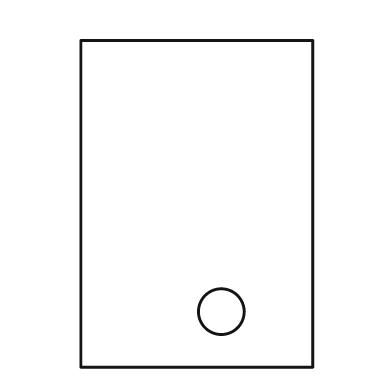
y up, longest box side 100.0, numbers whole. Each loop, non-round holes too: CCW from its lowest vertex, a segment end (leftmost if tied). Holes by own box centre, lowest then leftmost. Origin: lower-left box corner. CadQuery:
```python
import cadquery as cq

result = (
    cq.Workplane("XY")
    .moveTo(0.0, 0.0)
    .lineTo(71.0, 0.0)
    .lineTo(71.0, 100.0)
    .lineTo(0.0, 100.0)
    .close()
    .moveTo(43.0, 17.0)
    .circle(7.0)
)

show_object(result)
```